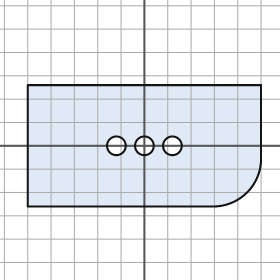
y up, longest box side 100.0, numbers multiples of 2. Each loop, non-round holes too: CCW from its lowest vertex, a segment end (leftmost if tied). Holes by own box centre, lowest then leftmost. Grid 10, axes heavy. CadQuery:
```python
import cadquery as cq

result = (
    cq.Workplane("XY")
    .moveTo(-50.0, -26.0)
    .lineTo(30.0, -26.0)
    .threePointArc((44.0, -20.0), (50.0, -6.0))
    .lineTo(50.0, 26.0)
    .lineTo(-50.0, 26.0)
    .close()
    .moveTo(-12.0, 0.0)
    .circle(4.0)
    .moveTo(0.0, 0.0)
    .circle(4.0)
    .moveTo(12.0, 0.0)
    .circle(4.0)
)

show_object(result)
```